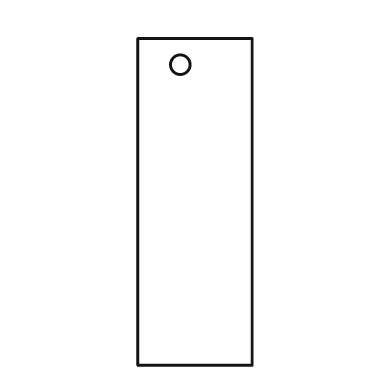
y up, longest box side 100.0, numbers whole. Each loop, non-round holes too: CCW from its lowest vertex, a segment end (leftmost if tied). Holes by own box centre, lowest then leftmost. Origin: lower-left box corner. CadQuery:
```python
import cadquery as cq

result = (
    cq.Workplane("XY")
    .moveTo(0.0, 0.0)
    .lineTo(35.0, 0.0)
    .lineTo(35.0, 100.0)
    .lineTo(0.0, 100.0)
    .close()
    .moveTo(13.0, 92.0)
    .circle(3.0)
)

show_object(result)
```